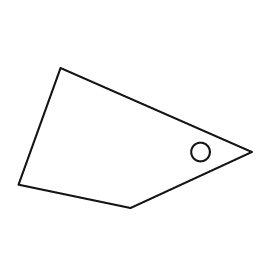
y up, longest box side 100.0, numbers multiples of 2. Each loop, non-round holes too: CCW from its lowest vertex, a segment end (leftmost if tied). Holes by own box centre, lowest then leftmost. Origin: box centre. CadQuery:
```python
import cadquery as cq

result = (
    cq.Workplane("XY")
    .moveTo(-2.0, -30.0)
    .lineTo(50.0, -6.0)
    .lineTo(-32.0, 30.0)
    .lineTo(-50.0, -20.0)
    .close()
    .moveTo(28.0, -6.0)
    .circle(4.0)
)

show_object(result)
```